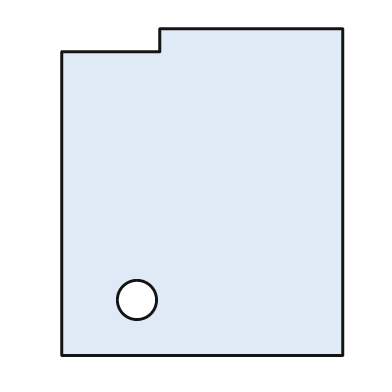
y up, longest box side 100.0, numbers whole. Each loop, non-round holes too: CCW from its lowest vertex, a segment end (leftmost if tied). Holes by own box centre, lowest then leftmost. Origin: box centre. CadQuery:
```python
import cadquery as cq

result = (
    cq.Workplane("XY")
    .moveTo(-43.0, -50.0)
    .lineTo(43.0, -50.0)
    .lineTo(43.0, 50.0)
    .lineTo(-13.0, 50.0)
    .lineTo(-13.0, 43.0)
    .lineTo(-43.0, 43.0)
    .close()
    .moveTo(-20.0, -33.0)
    .circle(6.0)
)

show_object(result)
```